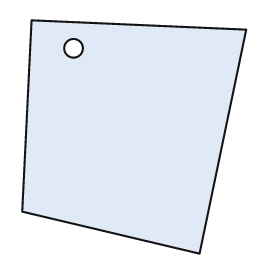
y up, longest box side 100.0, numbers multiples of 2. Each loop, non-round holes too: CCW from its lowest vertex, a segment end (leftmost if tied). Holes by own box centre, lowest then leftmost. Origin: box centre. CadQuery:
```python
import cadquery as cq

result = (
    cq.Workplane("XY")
    .moveTo(28.0, -50.0)
    .lineTo(48.0, 46.0)
    .lineTo(-44.0, 50.0)
    .lineTo(-48.0, -32.0)
    .close()
    .moveTo(-26.0, 38.0)
    .circle(4.0)
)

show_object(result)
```